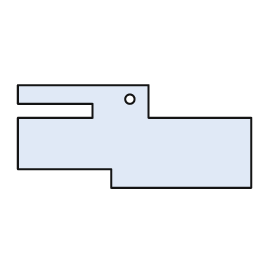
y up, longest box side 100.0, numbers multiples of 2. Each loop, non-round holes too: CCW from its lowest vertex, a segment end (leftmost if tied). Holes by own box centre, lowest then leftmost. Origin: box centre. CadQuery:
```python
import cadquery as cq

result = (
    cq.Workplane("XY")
    .moveTo(-10.0, -22.0)
    .lineTo(50.0, -22.0)
    .lineTo(50.0, 8.0)
    .lineTo(6.0, 8.0)
    .lineTo(6.0, 22.0)
    .lineTo(-50.0, 22.0)
    .lineTo(-50.0, 14.0)
    .lineTo(-18.0, 14.0)
    .lineTo(-18.0, 8.0)
    .lineTo(-50.0, 8.0)
    .lineTo(-50.0, -14.0)
    .lineTo(-10.0, -14.0)
    .close()
    .moveTo(-2.0, 16.0)
    .circle(2.0)
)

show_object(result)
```